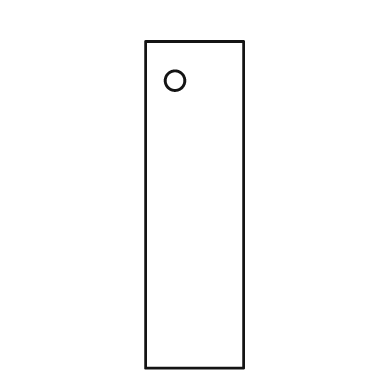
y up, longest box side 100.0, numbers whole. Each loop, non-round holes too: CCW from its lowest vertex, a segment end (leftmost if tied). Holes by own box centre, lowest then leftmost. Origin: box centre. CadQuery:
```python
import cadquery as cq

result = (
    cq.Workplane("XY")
    .moveTo(-15.0, -50.0)
    .lineTo(15.0, -50.0)
    .lineTo(15.0, 50.0)
    .lineTo(-15.0, 50.0)
    .close()
    .moveTo(-6.0, 38.0)
    .circle(3.0)
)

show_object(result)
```